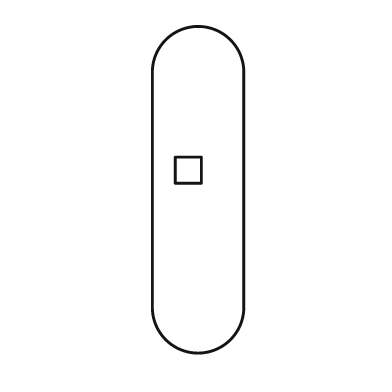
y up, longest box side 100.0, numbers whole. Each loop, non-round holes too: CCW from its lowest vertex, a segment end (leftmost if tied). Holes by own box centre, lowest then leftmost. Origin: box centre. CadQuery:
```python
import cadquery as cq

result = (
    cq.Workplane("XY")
    .moveTo(-14.0, -36.0)
    .threePointArc((0.0, -50.0), (14.0, -36.0))
    .lineTo(14.0, 36.0)
    .threePointArc((0.0, 50.0), (-14.0, 36.0))
    .close()
    .moveTo(-7.0, 2.0)
    .lineTo(1.0, 2.0)
    .lineTo(1.0, 10.0)
    .lineTo(-7.0, 10.0)
    .close()
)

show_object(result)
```